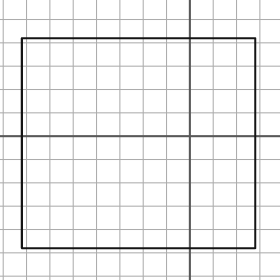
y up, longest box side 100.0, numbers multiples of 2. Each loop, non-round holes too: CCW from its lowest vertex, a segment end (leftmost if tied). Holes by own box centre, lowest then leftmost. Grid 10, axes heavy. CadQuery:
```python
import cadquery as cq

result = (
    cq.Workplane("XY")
    .moveTo(-72.0, -48.0)
    .lineTo(28.0, -48.0)
    .lineTo(28.0, 42.0)
    .lineTo(-72.0, 42.0)
    .close()
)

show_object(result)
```